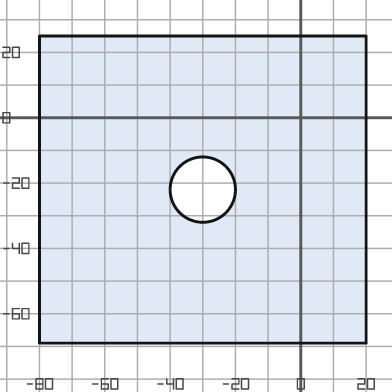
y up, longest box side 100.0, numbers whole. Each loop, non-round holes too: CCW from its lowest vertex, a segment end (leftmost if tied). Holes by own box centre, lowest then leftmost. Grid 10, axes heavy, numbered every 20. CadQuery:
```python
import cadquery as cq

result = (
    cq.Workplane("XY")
    .moveTo(-80.0, -69.0)
    .lineTo(20.0, -69.0)
    .lineTo(20.0, 25.0)
    .lineTo(-80.0, 25.0)
    .close()
    .moveTo(-30.0, -22.0)
    .circle(10.0)
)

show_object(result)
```